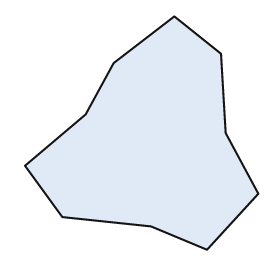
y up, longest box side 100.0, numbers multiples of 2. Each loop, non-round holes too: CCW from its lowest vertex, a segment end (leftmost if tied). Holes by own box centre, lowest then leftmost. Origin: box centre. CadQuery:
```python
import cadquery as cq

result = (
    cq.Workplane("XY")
    .moveTo(28.0, -50.0)
    .lineTo(50.0, -26.0)
    .lineTo(36.0, 0.0)
    .lineTo(34.0, 34.0)
    .lineTo(14.0, 50.0)
    .lineTo(-12.0, 30.0)
    .lineTo(-24.0, 8.0)
    .lineTo(-50.0, -14.0)
    .lineTo(-34.0, -36.0)
    .lineTo(4.0, -40.0)
    .close()
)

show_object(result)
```